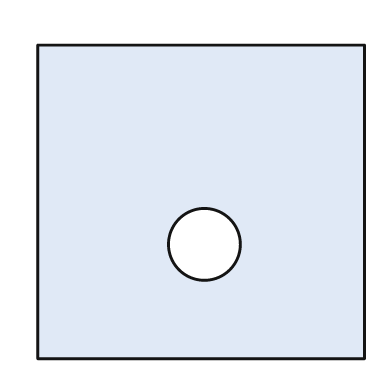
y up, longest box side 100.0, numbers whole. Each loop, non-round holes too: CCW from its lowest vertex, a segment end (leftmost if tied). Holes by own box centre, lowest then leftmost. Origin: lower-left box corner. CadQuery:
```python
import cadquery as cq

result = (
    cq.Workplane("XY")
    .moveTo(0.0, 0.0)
    .lineTo(100.0, 0.0)
    .lineTo(100.0, 96.0)
    .lineTo(0.0, 96.0)
    .close()
    .moveTo(51.0, 35.0)
    .circle(11.0)
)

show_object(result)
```